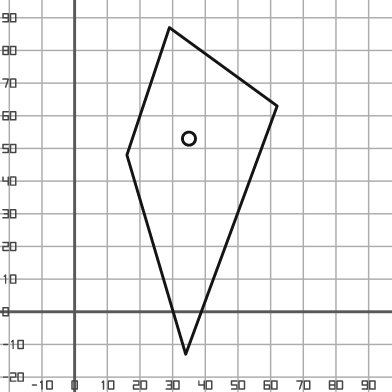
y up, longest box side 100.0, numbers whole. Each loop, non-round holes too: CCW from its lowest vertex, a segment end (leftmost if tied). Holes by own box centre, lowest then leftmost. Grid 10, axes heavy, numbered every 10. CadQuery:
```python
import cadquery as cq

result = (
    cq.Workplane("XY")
    .moveTo(34.0, -13.0)
    .lineTo(62.0, 63.0)
    .lineTo(29.0, 87.0)
    .lineTo(16.0, 48.0)
    .close()
    .moveTo(35.0, 53.0)
    .circle(2.0)
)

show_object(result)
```